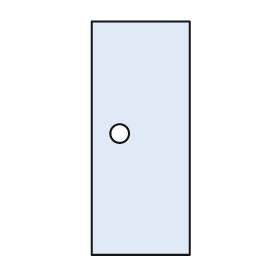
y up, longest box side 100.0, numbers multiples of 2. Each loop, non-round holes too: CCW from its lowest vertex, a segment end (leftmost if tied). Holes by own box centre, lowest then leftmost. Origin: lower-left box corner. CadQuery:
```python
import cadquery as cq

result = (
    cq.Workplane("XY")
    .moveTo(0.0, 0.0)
    .lineTo(42.0, 0.0)
    .lineTo(42.0, 100.0)
    .lineTo(0.0, 100.0)
    .close()
    .moveTo(12.0, 52.0)
    .circle(4.0)
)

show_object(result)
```